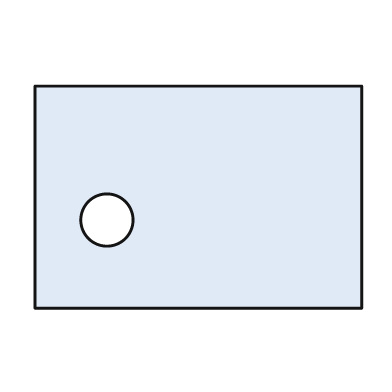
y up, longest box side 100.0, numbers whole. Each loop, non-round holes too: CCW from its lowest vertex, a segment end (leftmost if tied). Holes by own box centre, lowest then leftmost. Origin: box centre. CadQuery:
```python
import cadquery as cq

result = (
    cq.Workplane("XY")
    .moveTo(-50.0, -34.0)
    .lineTo(50.0, -34.0)
    .lineTo(50.0, 34.0)
    .lineTo(-50.0, 34.0)
    .close()
    .moveTo(-28.0, -7.0)
    .circle(8.0)
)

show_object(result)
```